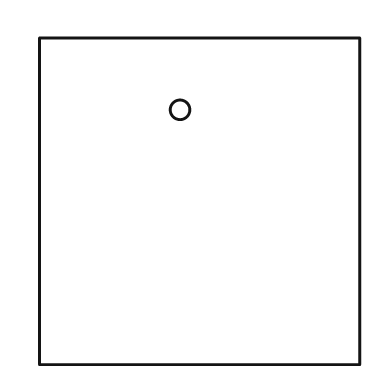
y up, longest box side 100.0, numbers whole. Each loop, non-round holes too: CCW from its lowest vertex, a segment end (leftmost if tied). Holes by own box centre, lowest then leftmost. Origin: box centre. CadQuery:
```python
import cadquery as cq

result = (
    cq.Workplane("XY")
    .moveTo(-49.0, -50.0)
    .lineTo(49.0, -50.0)
    .lineTo(49.0, 50.0)
    .lineTo(-49.0, 50.0)
    .close()
    .moveTo(-6.0, 28.0)
    .circle(3.0)
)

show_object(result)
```